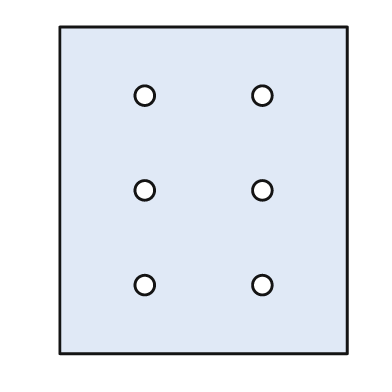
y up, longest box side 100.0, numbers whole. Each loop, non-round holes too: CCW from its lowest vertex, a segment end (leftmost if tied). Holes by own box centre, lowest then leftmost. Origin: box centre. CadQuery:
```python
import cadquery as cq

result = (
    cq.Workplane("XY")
    .moveTo(-44.0, -50.0)
    .lineTo(44.0, -50.0)
    .lineTo(44.0, 50.0)
    .lineTo(-44.0, 50.0)
    .close()
    .moveTo(-18.0, -29.0)
    .circle(3.0)
    .moveTo(18.0, -29.0)
    .circle(3.0)
    .moveTo(-18.0, 0.0)
    .circle(3.0)
    .moveTo(18.0, 0.0)
    .circle(3.0)
    .moveTo(-18.0, 29.0)
    .circle(3.0)
    .moveTo(18.0, 29.0)
    .circle(3.0)
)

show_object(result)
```